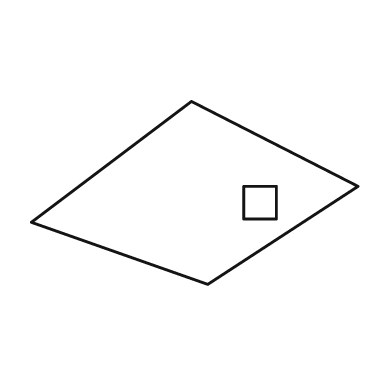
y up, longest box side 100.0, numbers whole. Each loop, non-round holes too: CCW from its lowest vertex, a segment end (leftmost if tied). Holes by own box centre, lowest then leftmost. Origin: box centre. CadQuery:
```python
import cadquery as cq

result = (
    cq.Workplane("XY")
    .moveTo(4.0, -28.0)
    .lineTo(50.0, 2.0)
    .lineTo(-1.0, 28.0)
    .lineTo(-50.0, -9.0)
    .close()
    .moveTo(15.0, -8.0)
    .lineTo(25.0, -8.0)
    .lineTo(25.0, 2.0)
    .lineTo(15.0, 2.0)
    .close()
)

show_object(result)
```